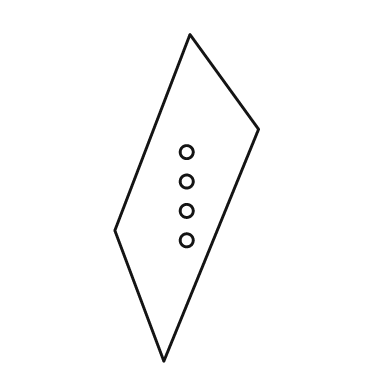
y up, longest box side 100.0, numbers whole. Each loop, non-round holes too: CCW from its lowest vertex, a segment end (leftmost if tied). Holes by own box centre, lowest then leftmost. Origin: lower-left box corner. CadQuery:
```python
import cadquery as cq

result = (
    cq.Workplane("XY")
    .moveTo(15.0, 0.0)
    .lineTo(44.0, 71.0)
    .lineTo(23.0, 100.0)
    .lineTo(0.0, 40.0)
    .close()
    .moveTo(22.0, 37.0)
    .circle(2.0)
    .moveTo(22.0, 46.0)
    .circle(2.0)
    .moveTo(22.0, 55.0)
    .circle(2.0)
    .moveTo(22.0, 64.0)
    .circle(2.0)
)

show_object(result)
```